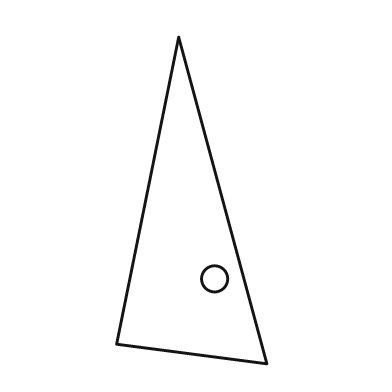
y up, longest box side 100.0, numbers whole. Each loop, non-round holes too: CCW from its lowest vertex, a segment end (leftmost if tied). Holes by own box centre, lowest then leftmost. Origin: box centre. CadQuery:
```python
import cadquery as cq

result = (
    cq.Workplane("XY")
    .moveTo(23.0, -50.0)
    .lineTo(-4.0, 50.0)
    .lineTo(-23.0, -44.0)
    .close()
    .moveTo(7.0, -24.0)
    .circle(4.0)
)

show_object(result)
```